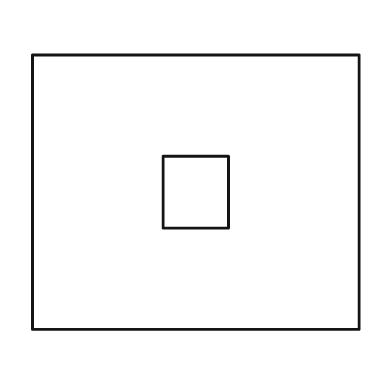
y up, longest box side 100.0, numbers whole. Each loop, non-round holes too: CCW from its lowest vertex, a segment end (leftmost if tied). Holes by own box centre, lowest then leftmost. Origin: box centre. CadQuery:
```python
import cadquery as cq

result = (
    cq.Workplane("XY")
    .moveTo(-50.0, -42.0)
    .lineTo(50.0, -42.0)
    .lineTo(50.0, 42.0)
    .lineTo(-50.0, 42.0)
    .close()
    .moveTo(-10.0, -11.0)
    .lineTo(10.0, -11.0)
    .lineTo(10.0, 11.0)
    .lineTo(-10.0, 11.0)
    .close()
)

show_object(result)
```